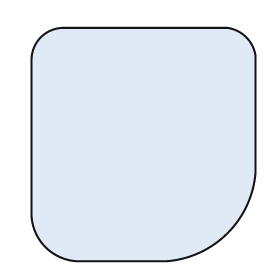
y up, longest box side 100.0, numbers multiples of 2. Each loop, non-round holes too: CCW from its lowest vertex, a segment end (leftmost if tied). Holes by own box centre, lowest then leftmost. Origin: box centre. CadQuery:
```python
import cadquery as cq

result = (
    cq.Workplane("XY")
    .moveTo(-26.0, -50.0)
    .lineTo(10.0, -50.0)
    .threePointArc((36.0, -38.0), (48.0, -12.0))
    .lineTo(48.0, 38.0)
    .threePointArc((44.0, 46.0), (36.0, 50.0))
    .lineTo(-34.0, 50.0)
    .threePointArc((-44.0, 46.0), (-48.0, 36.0))
    .lineTo(-48.0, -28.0)
    .threePointArc((-42.0, -44.0), (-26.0, -50.0))
    .close()
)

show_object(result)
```